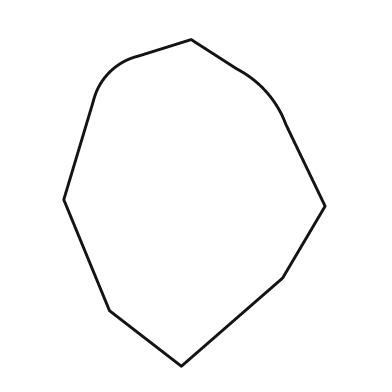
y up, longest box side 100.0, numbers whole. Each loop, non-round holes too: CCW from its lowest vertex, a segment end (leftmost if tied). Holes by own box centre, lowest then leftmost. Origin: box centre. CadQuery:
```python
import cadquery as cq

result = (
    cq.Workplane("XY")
    .moveTo(-4.0, -50.0)
    .lineTo(27.0, -23.0)
    .lineTo(40.0, -1.0)
    .lineTo(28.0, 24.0)
    .threePointArc((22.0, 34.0), (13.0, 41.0))
    .lineTo(-1.0, 50.0)
    .lineTo(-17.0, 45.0)
    .threePointArc((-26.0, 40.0), (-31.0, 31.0))
    .lineTo(-40.0, 1.0)
    .lineTo(-26.0, -33.0)
    .close()
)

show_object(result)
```